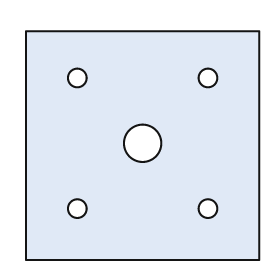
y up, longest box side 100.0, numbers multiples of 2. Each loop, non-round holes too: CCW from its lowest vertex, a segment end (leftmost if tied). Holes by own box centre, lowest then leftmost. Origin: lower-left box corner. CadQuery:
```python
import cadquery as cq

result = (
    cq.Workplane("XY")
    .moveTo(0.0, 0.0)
    .lineTo(100.0, 0.0)
    .lineTo(100.0, 98.0)
    .lineTo(0.0, 98.0)
    .close()
    .moveTo(22.0, 22.0)
    .circle(4.0)
    .moveTo(78.0, 22.0)
    .circle(4.0)
    .moveTo(50.0, 50.0)
    .circle(8.0)
    .moveTo(22.0, 78.0)
    .circle(4.0)
    .moveTo(78.0, 78.0)
    .circle(4.0)
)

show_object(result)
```